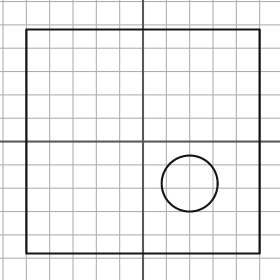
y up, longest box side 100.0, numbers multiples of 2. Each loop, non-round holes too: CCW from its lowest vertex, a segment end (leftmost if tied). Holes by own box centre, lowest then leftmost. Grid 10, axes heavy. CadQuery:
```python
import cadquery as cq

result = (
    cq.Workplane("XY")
    .moveTo(-50.0, -48.0)
    .lineTo(50.0, -48.0)
    .lineTo(50.0, 48.0)
    .lineTo(-50.0, 48.0)
    .close()
    .moveTo(20.0, -18.0)
    .circle(12.0)
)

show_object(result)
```